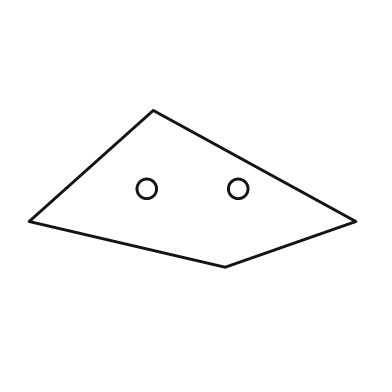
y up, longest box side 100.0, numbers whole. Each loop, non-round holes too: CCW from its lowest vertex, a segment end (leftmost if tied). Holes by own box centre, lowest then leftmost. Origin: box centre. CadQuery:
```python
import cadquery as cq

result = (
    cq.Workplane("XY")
    .moveTo(10.0, -24.0)
    .lineTo(50.0, -10.0)
    .lineTo(-12.0, 24.0)
    .lineTo(-50.0, -10.0)
    .close()
    .moveTo(-14.0, 0.0)
    .circle(3.0)
    .moveTo(14.0, 0.0)
    .circle(3.0)
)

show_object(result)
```